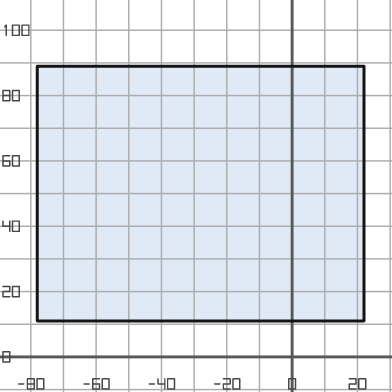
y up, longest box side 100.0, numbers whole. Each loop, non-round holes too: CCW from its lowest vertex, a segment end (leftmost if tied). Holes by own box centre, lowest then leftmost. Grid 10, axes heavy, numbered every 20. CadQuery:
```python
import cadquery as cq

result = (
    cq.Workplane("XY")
    .moveTo(-78.0, 11.0)
    .lineTo(22.0, 11.0)
    .lineTo(22.0, 89.0)
    .lineTo(-78.0, 89.0)
    .close()
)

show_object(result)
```